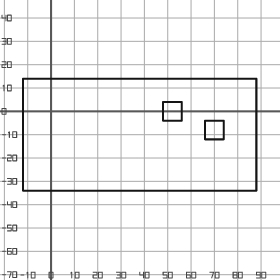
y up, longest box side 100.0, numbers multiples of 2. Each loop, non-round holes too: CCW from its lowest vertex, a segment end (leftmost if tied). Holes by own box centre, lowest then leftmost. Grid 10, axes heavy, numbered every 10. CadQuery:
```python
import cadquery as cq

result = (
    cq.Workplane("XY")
    .moveTo(-12.0, -34.0)
    .lineTo(88.0, -34.0)
    .lineTo(88.0, 14.0)
    .lineTo(-12.0, 14.0)
    .close()
    .moveTo(66.0, -12.0)
    .lineTo(74.0, -12.0)
    .lineTo(74.0, -4.0)
    .lineTo(66.0, -4.0)
    .close()
    .moveTo(48.0, -4.0)
    .lineTo(56.0, -4.0)
    .lineTo(56.0, 4.0)
    .lineTo(48.0, 4.0)
    .close()
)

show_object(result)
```